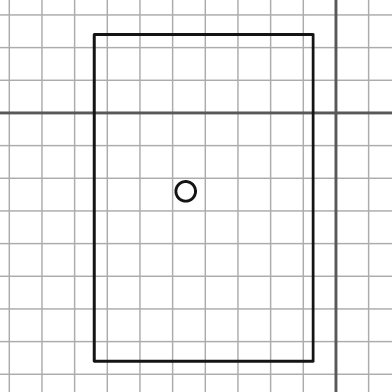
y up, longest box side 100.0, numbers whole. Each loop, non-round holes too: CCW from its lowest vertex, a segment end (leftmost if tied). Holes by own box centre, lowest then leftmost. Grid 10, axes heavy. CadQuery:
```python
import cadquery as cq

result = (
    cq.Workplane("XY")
    .moveTo(-74.0, -76.0)
    .lineTo(-7.0, -76.0)
    .lineTo(-7.0, 24.0)
    .lineTo(-74.0, 24.0)
    .close()
    .moveTo(-46.0, -24.0)
    .circle(3.0)
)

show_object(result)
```